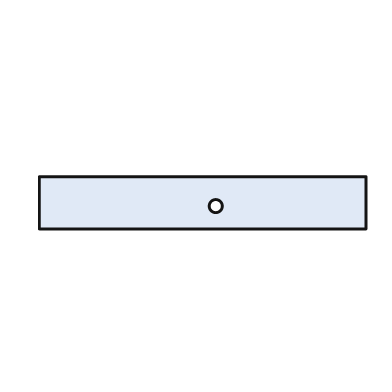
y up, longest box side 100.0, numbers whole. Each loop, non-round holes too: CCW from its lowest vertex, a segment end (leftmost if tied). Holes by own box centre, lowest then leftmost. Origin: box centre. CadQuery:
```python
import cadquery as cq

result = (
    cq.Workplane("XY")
    .moveTo(-50.0, -8.0)
    .lineTo(50.0, -8.0)
    .lineTo(50.0, 8.0)
    .lineTo(-50.0, 8.0)
    .close()
    .moveTo(4.0, -1.0)
    .circle(2.0)
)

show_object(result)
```